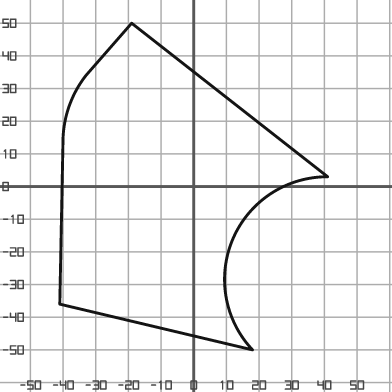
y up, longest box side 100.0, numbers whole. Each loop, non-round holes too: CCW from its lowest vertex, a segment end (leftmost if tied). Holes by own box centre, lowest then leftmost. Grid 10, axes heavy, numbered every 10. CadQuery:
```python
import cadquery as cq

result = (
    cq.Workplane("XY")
    .moveTo(18.0, -50.0)
    .threePointArc((12.0, -16.0), (41.0, 3.0))
    .lineTo(-19.0, 50.0)
    .lineTo(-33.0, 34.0)
    .threePointArc((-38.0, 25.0), (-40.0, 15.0))
    .lineTo(-41.0, -36.0)
    .close()
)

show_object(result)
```